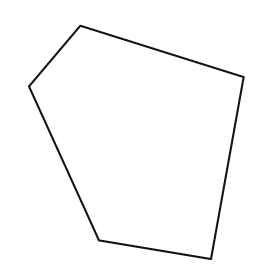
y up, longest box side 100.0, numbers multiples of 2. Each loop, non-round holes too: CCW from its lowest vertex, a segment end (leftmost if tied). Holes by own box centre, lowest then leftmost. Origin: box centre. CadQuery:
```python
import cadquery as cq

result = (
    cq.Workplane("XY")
    .moveTo(32.0, -50.0)
    .lineTo(46.0, 28.0)
    .lineTo(-24.0, 50.0)
    .lineTo(-46.0, 24.0)
    .lineTo(-16.0, -42.0)
    .close()
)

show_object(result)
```